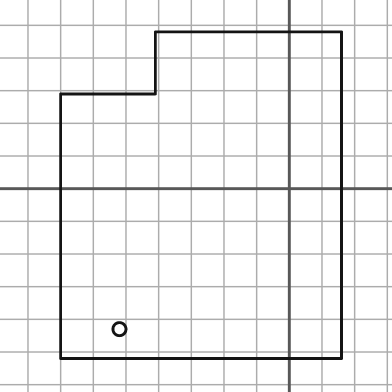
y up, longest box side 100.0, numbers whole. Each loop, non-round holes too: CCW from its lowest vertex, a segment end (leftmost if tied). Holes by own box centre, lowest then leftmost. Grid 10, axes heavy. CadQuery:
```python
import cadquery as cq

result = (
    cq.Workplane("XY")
    .moveTo(-70.0, -52.0)
    .lineTo(16.0, -52.0)
    .lineTo(16.0, 48.0)
    .lineTo(-41.0, 48.0)
    .lineTo(-41.0, 29.0)
    .lineTo(-70.0, 29.0)
    .close()
    .moveTo(-52.0, -43.0)
    .circle(2.0)
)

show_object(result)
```